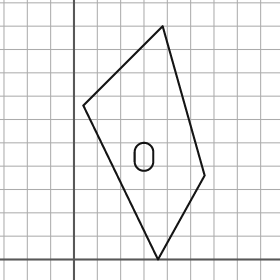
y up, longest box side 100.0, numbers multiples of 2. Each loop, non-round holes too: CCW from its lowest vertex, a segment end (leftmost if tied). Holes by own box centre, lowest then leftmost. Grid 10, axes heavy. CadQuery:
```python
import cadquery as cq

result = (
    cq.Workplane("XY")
    .moveTo(36.0, 0.0)
    .lineTo(56.0, 36.0)
    .lineTo(38.0, 100.0)
    .lineTo(4.0, 66.0)
    .close()
    .moveTo(26.0, 42.0)
    .threePointArc((30.0, 38.0), (34.0, 42.0))
    .lineTo(34.0, 46.0)
    .threePointArc((30.0, 50.0), (26.0, 46.0))
    .close()
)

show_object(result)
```